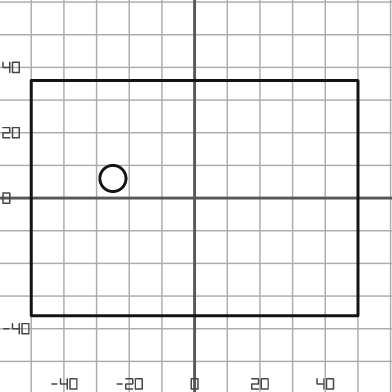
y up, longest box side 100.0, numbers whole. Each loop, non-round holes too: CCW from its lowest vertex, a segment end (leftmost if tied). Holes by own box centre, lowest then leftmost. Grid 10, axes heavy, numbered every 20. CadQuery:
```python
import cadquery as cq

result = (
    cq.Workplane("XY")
    .moveTo(-50.0, -36.0)
    .lineTo(50.0, -36.0)
    .lineTo(50.0, 36.0)
    .lineTo(-50.0, 36.0)
    .close()
    .moveTo(-25.0, 6.0)
    .circle(4.0)
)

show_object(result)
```